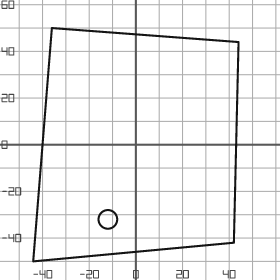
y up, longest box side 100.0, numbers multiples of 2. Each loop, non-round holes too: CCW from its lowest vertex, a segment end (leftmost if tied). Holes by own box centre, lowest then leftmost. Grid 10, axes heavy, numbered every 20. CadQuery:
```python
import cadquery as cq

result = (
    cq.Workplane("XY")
    .moveTo(-44.0, -50.0)
    .lineTo(42.0, -42.0)
    .lineTo(44.0, 44.0)
    .lineTo(-36.0, 50.0)
    .close()
    .moveTo(-12.0, -32.0)
    .circle(4.0)
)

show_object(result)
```